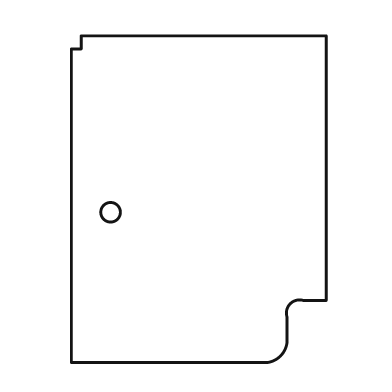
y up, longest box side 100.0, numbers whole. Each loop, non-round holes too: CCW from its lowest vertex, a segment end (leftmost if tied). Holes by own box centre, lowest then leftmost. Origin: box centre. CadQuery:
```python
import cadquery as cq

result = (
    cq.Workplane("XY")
    .moveTo(-39.0, -50.0)
    .lineTo(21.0, -50.0)
    .threePointArc((25.0, -48.0), (27.0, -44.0))
    .lineTo(27.0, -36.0)
    .threePointArc((28.0, -32.0), (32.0, -31.0))
    .lineTo(39.0, -31.0)
    .lineTo(39.0, 50.0)
    .lineTo(-36.0, 50.0)
    .lineTo(-36.0, 46.0)
    .lineTo(-39.0, 46.0)
    .close()
    .moveTo(-27.0, -4.0)
    .circle(3.0)
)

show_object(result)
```